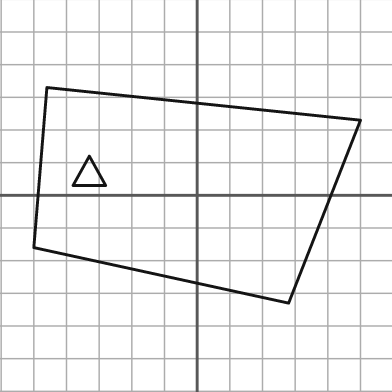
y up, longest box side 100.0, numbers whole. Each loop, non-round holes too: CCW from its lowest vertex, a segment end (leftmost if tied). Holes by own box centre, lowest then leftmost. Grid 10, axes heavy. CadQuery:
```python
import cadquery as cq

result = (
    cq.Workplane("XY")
    .moveTo(28.0, -33.0)
    .lineTo(50.0, 23.0)
    .lineTo(-46.0, 33.0)
    .lineTo(-50.0, -16.0)
    .close()
    .moveTo(-38.0, 3.0)
    .lineTo(-28.0, 3.0)
    .lineTo(-33.0, 12.0)
    .close()
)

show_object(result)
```